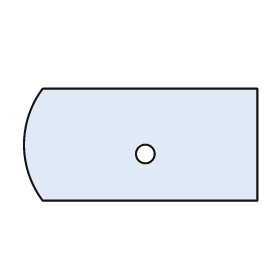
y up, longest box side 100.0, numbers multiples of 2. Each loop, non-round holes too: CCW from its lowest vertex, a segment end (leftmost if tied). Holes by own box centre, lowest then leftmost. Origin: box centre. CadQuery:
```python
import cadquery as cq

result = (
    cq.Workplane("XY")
    .moveTo(-42.0, -24.0)
    .lineTo(50.0, -24.0)
    .lineTo(50.0, 24.0)
    .lineTo(-42.0, 24.0)
    .threePointArc((-50.0, 0.0), (-42.0, -24.0))
    .close()
    .moveTo(2.0, -4.0)
    .circle(4.0)
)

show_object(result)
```